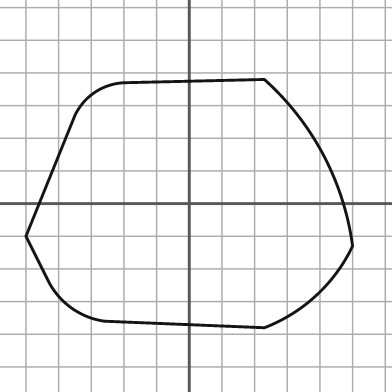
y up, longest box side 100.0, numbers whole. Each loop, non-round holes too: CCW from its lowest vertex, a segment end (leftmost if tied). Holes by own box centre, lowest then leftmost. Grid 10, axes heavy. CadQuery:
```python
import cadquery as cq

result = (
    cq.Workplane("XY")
    .moveTo(23.0, -38.0)
    .threePointArc((39.0, -28.0), (50.0, -13.0))
    .threePointArc((41.0, 15.0), (23.0, 38.0))
    .lineTo(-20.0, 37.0)
    .threePointArc((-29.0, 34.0), (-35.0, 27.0))
    .lineTo(-50.0, -10.0)
    .lineTo(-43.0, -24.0)
    .threePointArc((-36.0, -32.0), (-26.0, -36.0))
    .close()
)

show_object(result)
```